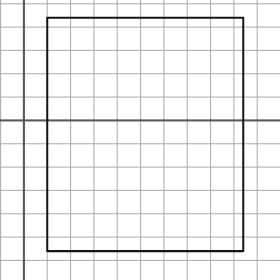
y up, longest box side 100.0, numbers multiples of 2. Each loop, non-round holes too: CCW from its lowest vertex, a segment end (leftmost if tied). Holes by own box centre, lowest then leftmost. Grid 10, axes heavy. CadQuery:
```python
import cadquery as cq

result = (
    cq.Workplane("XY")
    .moveTo(10.0, -56.0)
    .lineTo(94.0, -56.0)
    .lineTo(94.0, 44.0)
    .lineTo(10.0, 44.0)
    .close()
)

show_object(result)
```